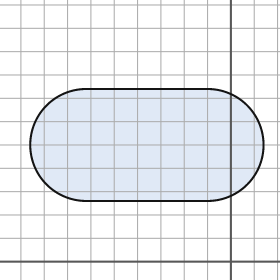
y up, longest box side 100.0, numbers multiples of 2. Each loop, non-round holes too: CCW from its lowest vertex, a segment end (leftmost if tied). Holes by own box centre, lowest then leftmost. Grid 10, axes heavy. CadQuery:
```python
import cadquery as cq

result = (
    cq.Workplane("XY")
    .moveTo(-62.0, 26.0)
    .lineTo(-10.0, 26.0)
    .threePointArc((14.0, 50.0), (-10.0, 74.0))
    .lineTo(-62.0, 74.0)
    .threePointArc((-86.0, 50.0), (-62.0, 26.0))
    .close()
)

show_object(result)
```